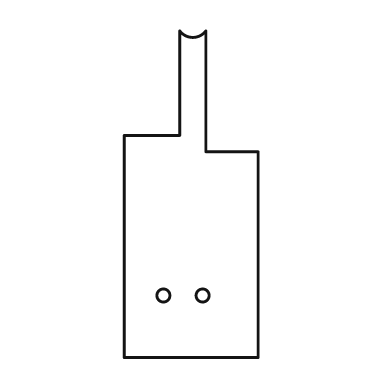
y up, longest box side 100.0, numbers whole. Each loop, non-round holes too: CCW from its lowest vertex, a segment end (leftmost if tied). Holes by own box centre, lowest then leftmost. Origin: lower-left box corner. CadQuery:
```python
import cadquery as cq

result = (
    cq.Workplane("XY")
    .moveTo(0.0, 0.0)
    .lineTo(41.0, 0.0)
    .lineTo(41.0, 63.0)
    .lineTo(25.0, 63.0)
    .lineTo(25.0, 100.0)
    .threePointArc((21.0, 98.0), (17.0, 100.0))
    .lineTo(17.0, 68.0)
    .lineTo(0.0, 68.0)
    .close()
    .moveTo(12.0, 19.0)
    .circle(2.0)
    .moveTo(24.0, 19.0)
    .circle(2.0)
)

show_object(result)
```